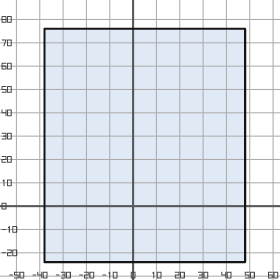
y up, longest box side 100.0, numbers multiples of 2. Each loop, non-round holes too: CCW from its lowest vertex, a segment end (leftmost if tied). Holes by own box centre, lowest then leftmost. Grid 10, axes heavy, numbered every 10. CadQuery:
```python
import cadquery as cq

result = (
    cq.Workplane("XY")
    .moveTo(-38.0, -24.0)
    .lineTo(48.0, -24.0)
    .lineTo(48.0, 76.0)
    .lineTo(-38.0, 76.0)
    .close()
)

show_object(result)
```